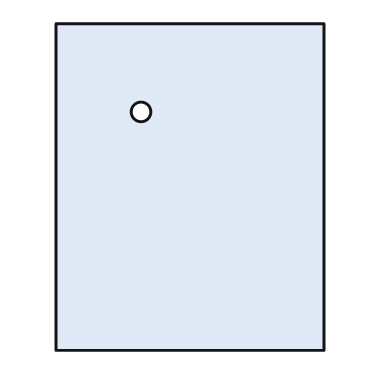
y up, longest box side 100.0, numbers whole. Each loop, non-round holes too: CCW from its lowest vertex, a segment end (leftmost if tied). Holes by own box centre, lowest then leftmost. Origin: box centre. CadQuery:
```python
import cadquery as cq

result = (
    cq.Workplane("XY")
    .moveTo(-41.0, -50.0)
    .lineTo(41.0, -50.0)
    .lineTo(41.0, 50.0)
    .lineTo(-41.0, 50.0)
    .close()
    .moveTo(-15.0, 23.0)
    .circle(3.0)
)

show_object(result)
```